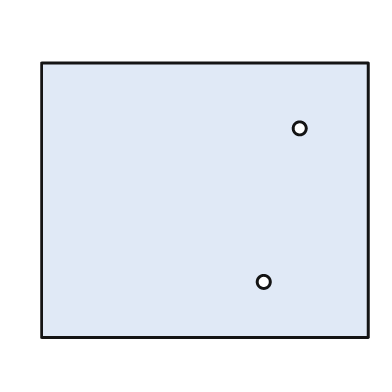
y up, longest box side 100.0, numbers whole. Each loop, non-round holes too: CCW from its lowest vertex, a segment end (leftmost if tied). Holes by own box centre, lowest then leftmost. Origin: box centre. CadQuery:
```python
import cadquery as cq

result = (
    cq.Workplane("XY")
    .moveTo(-50.0, -42.0)
    .lineTo(50.0, -42.0)
    .lineTo(50.0, 42.0)
    .lineTo(-50.0, 42.0)
    .close()
    .moveTo(18.0, -25.0)
    .circle(2.0)
    .moveTo(29.0, 22.0)
    .circle(2.0)
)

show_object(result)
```